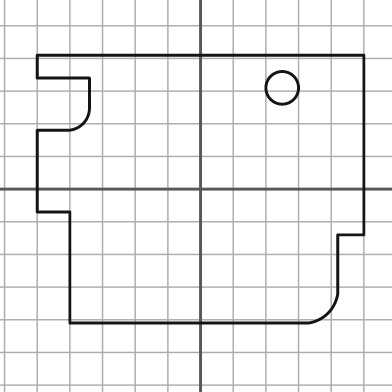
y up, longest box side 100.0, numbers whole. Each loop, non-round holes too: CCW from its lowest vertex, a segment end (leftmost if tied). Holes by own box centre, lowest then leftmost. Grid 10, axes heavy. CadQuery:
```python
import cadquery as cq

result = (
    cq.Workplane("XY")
    .moveTo(-40.0, -41.0)
    .lineTo(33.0, -41.0)
    .threePointArc((39.0, -38.0), (42.0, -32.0))
    .lineTo(42.0, -14.0)
    .lineTo(50.0, -14.0)
    .lineTo(50.0, 41.0)
    .lineTo(-50.0, 41.0)
    .lineTo(-50.0, 34.0)
    .lineTo(-34.0, 34.0)
    .lineTo(-34.0, 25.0)
    .threePointArc((-36.0, 20.0), (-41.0, 18.0))
    .lineTo(-50.0, 18.0)
    .lineTo(-50.0, -7.0)
    .lineTo(-40.0, -7.0)
    .close()
    .moveTo(25.0, 31.0)
    .circle(5.0)
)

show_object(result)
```